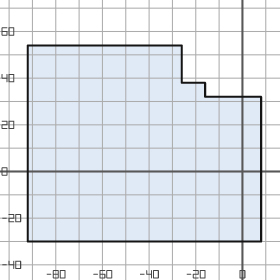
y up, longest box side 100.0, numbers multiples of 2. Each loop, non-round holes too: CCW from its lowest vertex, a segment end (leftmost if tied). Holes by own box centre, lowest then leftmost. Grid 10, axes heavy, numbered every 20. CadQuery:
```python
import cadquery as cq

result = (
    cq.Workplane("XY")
    .moveTo(-92.0, -30.0)
    .lineTo(8.0, -30.0)
    .lineTo(8.0, 32.0)
    .lineTo(-16.0, 32.0)
    .lineTo(-16.0, 38.0)
    .lineTo(-26.0, 38.0)
    .lineTo(-26.0, 54.0)
    .lineTo(-92.0, 54.0)
    .close()
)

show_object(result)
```